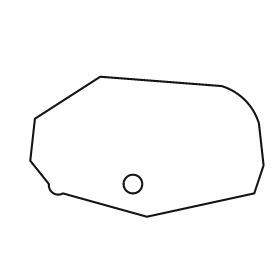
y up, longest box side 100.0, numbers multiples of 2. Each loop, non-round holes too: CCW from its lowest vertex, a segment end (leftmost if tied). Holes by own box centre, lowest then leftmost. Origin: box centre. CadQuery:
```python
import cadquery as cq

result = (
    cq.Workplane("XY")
    .moveTo(0.0, -30.0)
    .lineTo(46.0, -20.0)
    .lineTo(50.0, -8.0)
    .lineTo(48.0, 10.0)
    .threePointArc((42.0, 20.0), (32.0, 26.0))
    .lineTo(-20.0, 30.0)
    .lineTo(-48.0, 12.0)
    .lineTo(-50.0, -6.0)
    .lineTo(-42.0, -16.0)
    .threePointArc((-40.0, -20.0), (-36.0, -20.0))
    .close()
    .moveTo(-6.0, -16.0)
    .circle(4.0)
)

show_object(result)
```